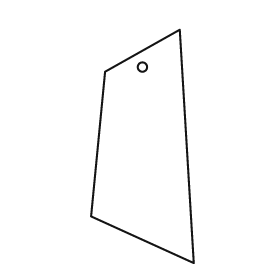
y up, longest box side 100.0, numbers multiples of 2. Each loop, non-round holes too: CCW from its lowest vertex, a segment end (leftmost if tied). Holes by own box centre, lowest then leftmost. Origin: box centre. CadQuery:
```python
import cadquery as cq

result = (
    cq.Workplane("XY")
    .moveTo(22.0, -50.0)
    .lineTo(16.0, 50.0)
    .lineTo(-16.0, 32.0)
    .lineTo(-22.0, -30.0)
    .close()
    .moveTo(0.0, 34.0)
    .circle(2.0)
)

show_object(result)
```